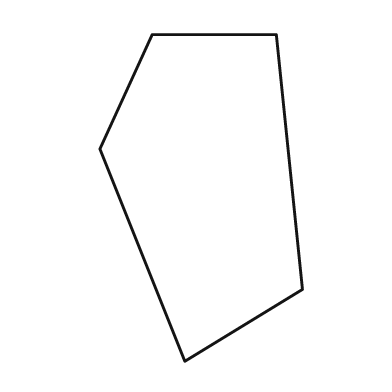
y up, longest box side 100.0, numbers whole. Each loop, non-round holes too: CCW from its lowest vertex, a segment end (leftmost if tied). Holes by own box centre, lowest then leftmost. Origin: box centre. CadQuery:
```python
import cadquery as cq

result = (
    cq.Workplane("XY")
    .moveTo(-5.0, -50.0)
    .lineTo(31.0, -28.0)
    .lineTo(23.0, 50.0)
    .lineTo(-15.0, 50.0)
    .lineTo(-31.0, 15.0)
    .close()
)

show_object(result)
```